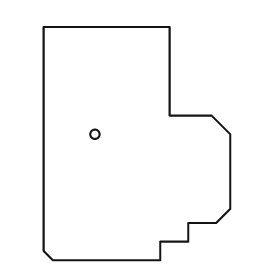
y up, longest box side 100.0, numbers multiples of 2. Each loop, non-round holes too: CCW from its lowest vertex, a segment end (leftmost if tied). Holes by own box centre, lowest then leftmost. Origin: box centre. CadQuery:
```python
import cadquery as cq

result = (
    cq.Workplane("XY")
    .moveTo(-36.0, -50.0)
    .lineTo(10.0, -50.0)
    .lineTo(10.0, -42.0)
    .lineTo(22.0, -42.0)
    .lineTo(22.0, -34.0)
    .lineTo(34.0, -34.0)
    .lineTo(40.0, -28.0)
    .lineTo(40.0, 4.0)
    .lineTo(32.0, 12.0)
    .lineTo(14.0, 12.0)
    .lineTo(14.0, 50.0)
    .lineTo(-40.0, 50.0)
    .lineTo(-40.0, -46.0)
    .close()
    .moveTo(-18.0, 4.0)
    .circle(2.0)
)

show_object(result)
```